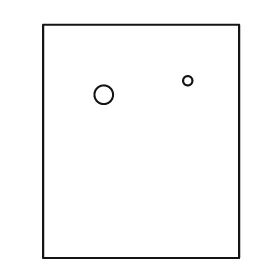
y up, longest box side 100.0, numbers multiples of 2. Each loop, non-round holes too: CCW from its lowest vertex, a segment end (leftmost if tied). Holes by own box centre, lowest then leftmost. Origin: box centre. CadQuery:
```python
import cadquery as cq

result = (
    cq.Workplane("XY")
    .moveTo(-42.0, -50.0)
    .lineTo(42.0, -50.0)
    .lineTo(42.0, 50.0)
    .lineTo(-42.0, 50.0)
    .close()
    .moveTo(-16.0, 20.0)
    .circle(4.0)
    .moveTo(20.0, 26.0)
    .circle(2.0)
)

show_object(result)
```